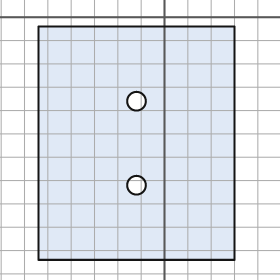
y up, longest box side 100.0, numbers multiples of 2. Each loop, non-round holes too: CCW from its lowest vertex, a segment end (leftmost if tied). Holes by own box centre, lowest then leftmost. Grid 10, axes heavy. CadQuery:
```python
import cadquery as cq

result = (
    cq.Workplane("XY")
    .moveTo(-54.0, -104.0)
    .lineTo(30.0, -104.0)
    .lineTo(30.0, -4.0)
    .lineTo(-54.0, -4.0)
    .close()
    .moveTo(-12.0, -72.0)
    .circle(4.0)
    .moveTo(-12.0, -36.0)
    .circle(4.0)
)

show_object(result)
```